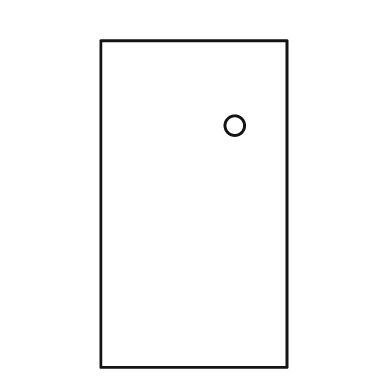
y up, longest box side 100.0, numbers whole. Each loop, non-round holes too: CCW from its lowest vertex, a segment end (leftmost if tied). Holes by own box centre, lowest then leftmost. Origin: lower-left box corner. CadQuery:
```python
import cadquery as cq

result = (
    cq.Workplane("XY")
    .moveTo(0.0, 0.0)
    .lineTo(57.0, 0.0)
    .lineTo(57.0, 100.0)
    .lineTo(0.0, 100.0)
    .close()
    .moveTo(41.0, 74.0)
    .circle(3.0)
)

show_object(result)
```